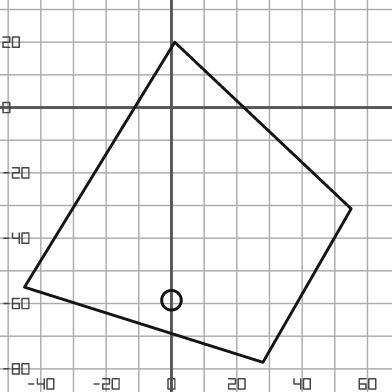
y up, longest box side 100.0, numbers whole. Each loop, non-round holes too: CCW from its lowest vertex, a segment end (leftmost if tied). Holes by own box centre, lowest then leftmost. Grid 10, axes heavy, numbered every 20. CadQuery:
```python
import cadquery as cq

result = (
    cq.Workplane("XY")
    .moveTo(28.0, -78.0)
    .lineTo(55.0, -31.0)
    .lineTo(1.0, 20.0)
    .lineTo(-45.0, -55.0)
    .close()
    .moveTo(0.0, -59.0)
    .circle(3.0)
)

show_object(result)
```